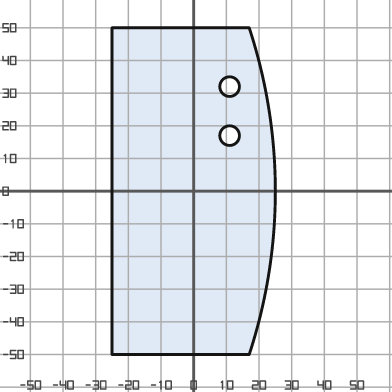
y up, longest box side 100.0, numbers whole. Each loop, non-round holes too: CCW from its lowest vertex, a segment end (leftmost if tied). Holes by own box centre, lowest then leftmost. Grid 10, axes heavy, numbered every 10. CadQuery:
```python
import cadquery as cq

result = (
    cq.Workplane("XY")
    .moveTo(-25.0, -50.0)
    .lineTo(17.0, -50.0)
    .threePointArc((25.0, 0.0), (17.0, 50.0))
    .lineTo(-25.0, 50.0)
    .close()
    .moveTo(11.0, 17.0)
    .circle(3.0)
    .moveTo(11.0, 32.0)
    .circle(3.0)
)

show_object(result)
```